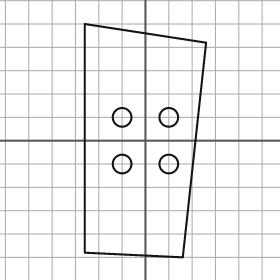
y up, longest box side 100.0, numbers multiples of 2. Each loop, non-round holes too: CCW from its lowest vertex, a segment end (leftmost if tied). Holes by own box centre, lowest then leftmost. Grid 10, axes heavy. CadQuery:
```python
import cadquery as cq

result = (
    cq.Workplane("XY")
    .moveTo(16.0, -50.0)
    .lineTo(26.0, 42.0)
    .lineTo(-26.0, 50.0)
    .lineTo(-26.0, -48.0)
    .close()
    .moveTo(-10.0, -10.0)
    .circle(4.0)
    .moveTo(10.0, -10.0)
    .circle(4.0)
    .moveTo(-10.0, 10.0)
    .circle(4.0)
    .moveTo(10.0, 10.0)
    .circle(4.0)
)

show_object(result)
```